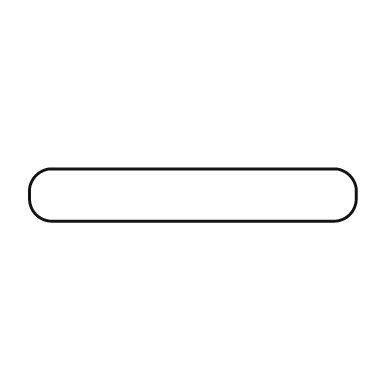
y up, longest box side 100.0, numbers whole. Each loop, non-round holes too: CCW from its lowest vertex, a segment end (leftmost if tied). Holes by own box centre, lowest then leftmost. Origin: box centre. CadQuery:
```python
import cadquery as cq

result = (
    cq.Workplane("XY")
    .moveTo(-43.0, -8.0)
    .lineTo(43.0, -8.0)
    .threePointArc((48.0, -6.0), (50.0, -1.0))
    .lineTo(50.0, 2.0)
    .threePointArc((48.0, 6.0), (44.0, 8.0))
    .lineTo(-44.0, 8.0)
    .threePointArc((-48.0, 6.0), (-50.0, 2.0))
    .lineTo(-50.0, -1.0)
    .threePointArc((-48.0, -6.0), (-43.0, -8.0))
    .close()
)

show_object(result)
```